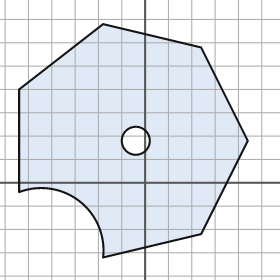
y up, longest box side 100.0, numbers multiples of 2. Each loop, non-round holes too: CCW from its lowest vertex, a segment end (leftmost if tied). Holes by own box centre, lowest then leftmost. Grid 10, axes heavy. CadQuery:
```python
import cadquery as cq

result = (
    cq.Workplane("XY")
    .moveTo(-18.0, -32.0)
    .lineTo(24.0, -22.0)
    .lineTo(44.0, 18.0)
    .lineTo(24.0, 58.0)
    .lineTo(-18.0, 68.0)
    .lineTo(-54.0, 40.0)
    .lineTo(-54.0, -4.0)
    .threePointArc((-28.0, -8.0), (-18.0, -32.0))
    .close()
    .moveTo(-4.0, 18.0)
    .circle(6.0)
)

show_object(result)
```